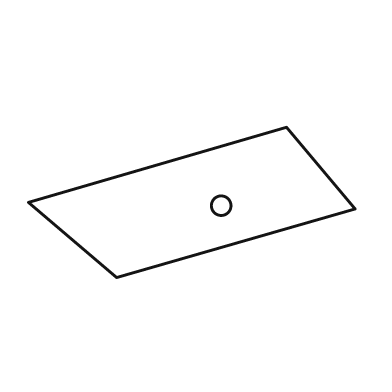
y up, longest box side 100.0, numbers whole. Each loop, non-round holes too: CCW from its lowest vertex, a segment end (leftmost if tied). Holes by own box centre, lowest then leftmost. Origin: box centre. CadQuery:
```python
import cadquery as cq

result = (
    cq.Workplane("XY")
    .moveTo(-23.0, -23.0)
    .lineTo(50.0, -2.0)
    .lineTo(29.0, 23.0)
    .lineTo(-50.0, 0.0)
    .close()
    .moveTo(9.0, -1.0)
    .circle(3.0)
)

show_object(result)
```